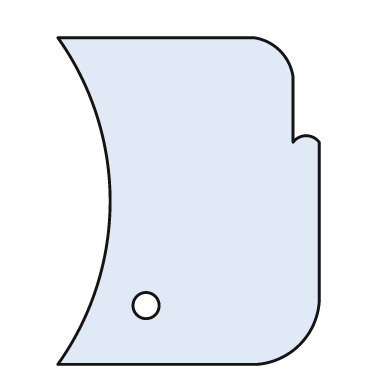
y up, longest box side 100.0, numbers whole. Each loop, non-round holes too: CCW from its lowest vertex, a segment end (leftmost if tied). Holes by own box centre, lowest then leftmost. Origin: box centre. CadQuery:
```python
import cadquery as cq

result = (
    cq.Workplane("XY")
    .moveTo(-40.0, -50.0)
    .lineTo(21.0, -50.0)
    .threePointArc((34.0, -44.0), (40.0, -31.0))
    .lineTo(40.0, 18.0)
    .threePointArc((36.0, 20.0), (32.0, 18.0))
    .lineTo(32.0, 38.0)
    .threePointArc((28.0, 46.0), (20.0, 50.0))
    .lineTo(-40.0, 50.0)
    .threePointArc((-24.0, 0.0), (-40.0, -50.0))
    .close()
    .moveTo(-13.0, -32.0)
    .circle(4.0)
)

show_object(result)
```